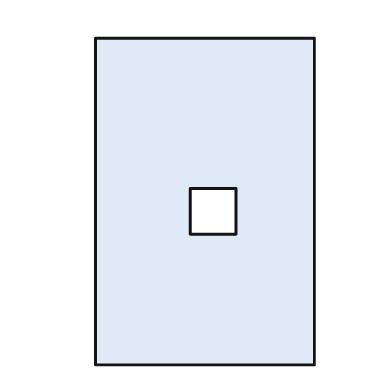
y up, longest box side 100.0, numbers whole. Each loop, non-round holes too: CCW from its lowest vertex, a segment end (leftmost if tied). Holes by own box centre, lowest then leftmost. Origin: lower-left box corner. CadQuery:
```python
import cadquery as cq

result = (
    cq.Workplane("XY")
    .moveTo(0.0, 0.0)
    .lineTo(67.0, 0.0)
    .lineTo(67.0, 100.0)
    .lineTo(0.0, 100.0)
    .close()
    .moveTo(29.0, 40.0)
    .lineTo(43.0, 40.0)
    .lineTo(43.0, 54.0)
    .lineTo(29.0, 54.0)
    .close()
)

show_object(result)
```